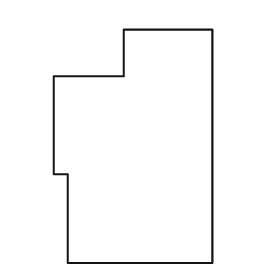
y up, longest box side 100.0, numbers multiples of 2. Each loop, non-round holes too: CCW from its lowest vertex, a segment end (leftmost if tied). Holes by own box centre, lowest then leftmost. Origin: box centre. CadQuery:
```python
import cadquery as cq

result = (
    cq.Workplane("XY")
    .moveTo(-28.0, -50.0)
    .lineTo(34.0, -50.0)
    .lineTo(34.0, 50.0)
    .lineTo(-4.0, 50.0)
    .lineTo(-4.0, 30.0)
    .lineTo(-34.0, 30.0)
    .lineTo(-34.0, -12.0)
    .lineTo(-28.0, -12.0)
    .close()
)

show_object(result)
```